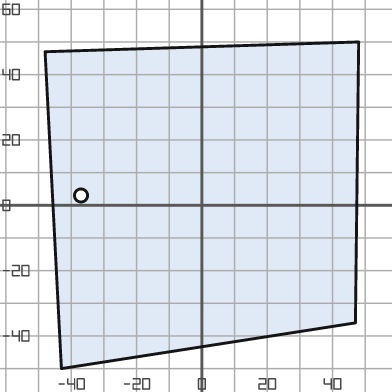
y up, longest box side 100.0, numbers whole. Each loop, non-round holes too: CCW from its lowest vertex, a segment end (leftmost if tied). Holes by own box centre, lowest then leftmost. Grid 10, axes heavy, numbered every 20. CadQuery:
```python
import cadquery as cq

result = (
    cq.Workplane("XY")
    .moveTo(-43.0, -50.0)
    .lineTo(47.0, -36.0)
    .lineTo(48.0, 50.0)
    .lineTo(-48.0, 47.0)
    .close()
    .moveTo(-37.0, 3.0)
    .circle(2.0)
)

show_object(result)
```